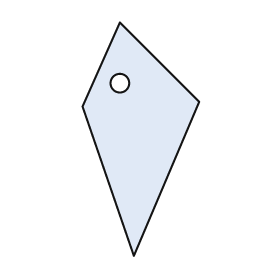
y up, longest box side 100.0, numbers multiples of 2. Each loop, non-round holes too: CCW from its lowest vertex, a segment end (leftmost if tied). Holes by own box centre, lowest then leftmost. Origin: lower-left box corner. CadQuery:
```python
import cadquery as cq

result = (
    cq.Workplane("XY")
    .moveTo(22.0, 0.0)
    .lineTo(50.0, 66.0)
    .lineTo(16.0, 100.0)
    .lineTo(0.0, 64.0)
    .close()
    .moveTo(16.0, 74.0)
    .circle(4.0)
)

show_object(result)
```